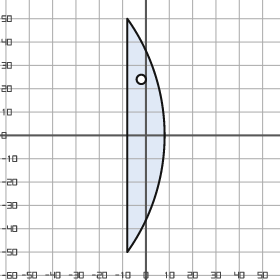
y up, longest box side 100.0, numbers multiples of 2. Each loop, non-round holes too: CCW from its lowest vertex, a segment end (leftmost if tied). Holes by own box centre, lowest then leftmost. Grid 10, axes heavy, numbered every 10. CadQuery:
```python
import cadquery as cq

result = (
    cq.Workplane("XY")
    .moveTo(-8.0, -50.0)
    .threePointArc((8.0, 0.0), (-8.0, 50.0))
    .close()
    .moveTo(-2.0, 24.0)
    .circle(2.0)
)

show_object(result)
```